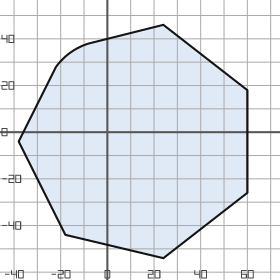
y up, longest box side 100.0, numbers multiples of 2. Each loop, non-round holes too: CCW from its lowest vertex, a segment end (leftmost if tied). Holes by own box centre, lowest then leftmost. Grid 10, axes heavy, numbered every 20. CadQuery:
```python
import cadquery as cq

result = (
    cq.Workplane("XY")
    .moveTo(24.0, -54.0)
    .lineTo(60.0, -26.0)
    .lineTo(60.0, 18.0)
    .lineTo(24.0, 46.0)
    .lineTo(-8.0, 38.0)
    .threePointArc((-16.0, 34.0), (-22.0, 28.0))
    .lineTo(-38.0, -4.0)
    .lineTo(-18.0, -44.0)
    .close()
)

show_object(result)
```